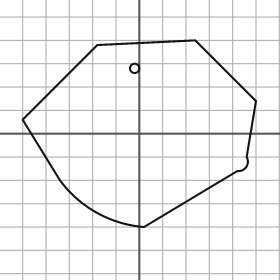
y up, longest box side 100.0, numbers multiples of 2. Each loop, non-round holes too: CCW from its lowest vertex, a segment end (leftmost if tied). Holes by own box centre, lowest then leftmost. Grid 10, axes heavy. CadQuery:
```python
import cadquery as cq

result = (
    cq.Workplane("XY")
    .moveTo(2.0, -40.0)
    .lineTo(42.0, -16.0)
    .threePointArc((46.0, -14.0), (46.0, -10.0))
    .lineTo(50.0, 14.0)
    .lineTo(24.0, 40.0)
    .lineTo(-18.0, 38.0)
    .lineTo(-50.0, 6.0)
    .lineTo(-34.0, -20.0)
    .threePointArc((-18.0, -34.0), (2.0, -40.0))
    .close()
    .moveTo(-2.0, 28.0)
    .circle(2.0)
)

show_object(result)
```